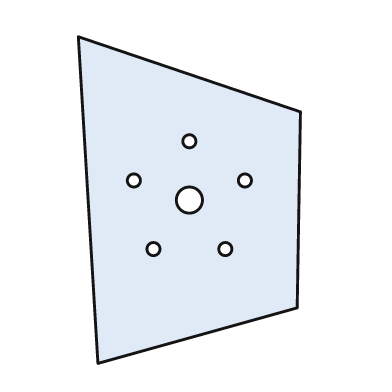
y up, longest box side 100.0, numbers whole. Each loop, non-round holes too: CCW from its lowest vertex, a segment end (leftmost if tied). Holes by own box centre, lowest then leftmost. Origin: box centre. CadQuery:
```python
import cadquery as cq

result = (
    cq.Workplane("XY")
    .moveTo(-28.0, -50.0)
    .lineTo(33.0, -33.0)
    .lineTo(34.0, 27.0)
    .lineTo(-34.0, 50.0)
    .close()
    .moveTo(-11.0, -15.0)
    .circle(2.0)
    .moveTo(11.0, -15.0)
    .circle(2.0)
    .moveTo(0.0, 0.0)
    .circle(4.0)
    .moveTo(-17.0, 6.0)
    .circle(2.0)
    .moveTo(17.0, 6.0)
    .circle(2.0)
    .moveTo(0.0, 18.0)
    .circle(2.0)
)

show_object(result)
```